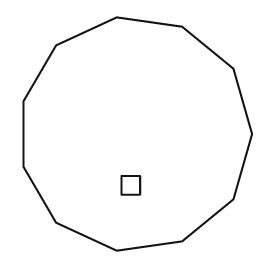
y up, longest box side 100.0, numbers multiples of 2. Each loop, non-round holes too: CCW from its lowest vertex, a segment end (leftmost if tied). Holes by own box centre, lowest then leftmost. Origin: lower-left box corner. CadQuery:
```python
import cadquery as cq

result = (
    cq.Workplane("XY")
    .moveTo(40.0, 0.0)
    .lineTo(68.0, 4.0)
    .lineTo(90.0, 22.0)
    .lineTo(98.0, 50.0)
    .lineTo(90.0, 78.0)
    .lineTo(68.0, 96.0)
    .lineTo(40.0, 100.0)
    .lineTo(14.0, 88.0)
    .lineTo(0.0, 64.0)
    .lineTo(0.0, 36.0)
    .lineTo(14.0, 12.0)
    .close()
    .moveTo(42.0, 24.0)
    .lineTo(50.0, 24.0)
    .lineTo(50.0, 32.0)
    .lineTo(42.0, 32.0)
    .close()
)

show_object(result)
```